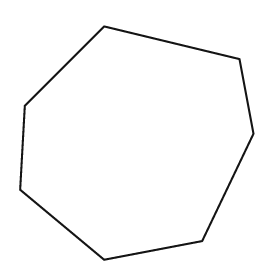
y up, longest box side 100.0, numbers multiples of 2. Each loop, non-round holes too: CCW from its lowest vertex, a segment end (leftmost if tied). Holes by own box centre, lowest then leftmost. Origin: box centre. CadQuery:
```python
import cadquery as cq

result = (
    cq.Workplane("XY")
    .moveTo(-14.0, -50.0)
    .lineTo(28.0, -42.0)
    .lineTo(50.0, 4.0)
    .lineTo(44.0, 36.0)
    .lineTo(-14.0, 50.0)
    .lineTo(-48.0, 16.0)
    .lineTo(-50.0, -20.0)
    .close()
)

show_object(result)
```